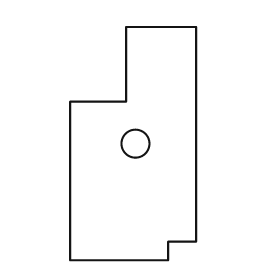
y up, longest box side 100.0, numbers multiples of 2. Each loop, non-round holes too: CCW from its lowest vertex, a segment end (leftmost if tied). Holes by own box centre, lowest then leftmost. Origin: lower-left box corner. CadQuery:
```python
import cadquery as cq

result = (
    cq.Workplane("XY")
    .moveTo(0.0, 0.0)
    .lineTo(42.0, 0.0)
    .lineTo(42.0, 8.0)
    .lineTo(54.0, 8.0)
    .lineTo(54.0, 100.0)
    .lineTo(24.0, 100.0)
    .lineTo(24.0, 68.0)
    .lineTo(0.0, 68.0)
    .close()
    .moveTo(28.0, 50.0)
    .circle(6.0)
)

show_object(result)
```